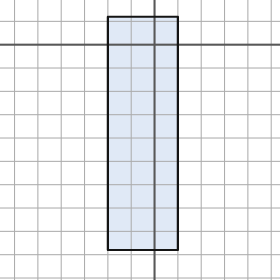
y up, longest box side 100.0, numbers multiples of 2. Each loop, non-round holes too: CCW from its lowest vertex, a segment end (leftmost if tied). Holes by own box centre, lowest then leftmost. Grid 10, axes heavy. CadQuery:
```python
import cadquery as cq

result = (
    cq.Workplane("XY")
    .moveTo(-20.0, -88.0)
    .lineTo(10.0, -88.0)
    .lineTo(10.0, 12.0)
    .lineTo(-20.0, 12.0)
    .close()
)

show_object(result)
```